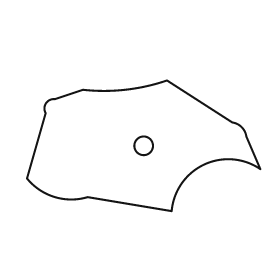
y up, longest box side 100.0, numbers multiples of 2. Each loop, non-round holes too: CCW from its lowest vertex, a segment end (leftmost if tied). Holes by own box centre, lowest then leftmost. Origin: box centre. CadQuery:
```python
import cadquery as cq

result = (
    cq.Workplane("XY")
    .moveTo(12.0, -28.0)
    .threePointArc((26.0, -8.0), (50.0, -10.0))
    .lineTo(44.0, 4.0)
    .threePointArc((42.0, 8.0), (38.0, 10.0))
    .lineTo(10.0, 28.0)
    .threePointArc((-8.0, 24.0), (-26.0, 24.0))
    .lineTo(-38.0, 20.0)
    .threePointArc((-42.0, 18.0), (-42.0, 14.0))
    .lineTo(-50.0, -14.0)
    .threePointArc((-38.0, -22.0), (-24.0, -22.0))
    .close()
    .moveTo(0.0, 0.0)
    .circle(4.0)
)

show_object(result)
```